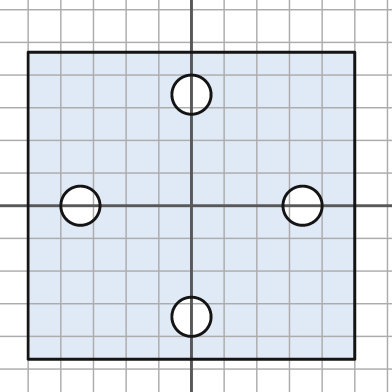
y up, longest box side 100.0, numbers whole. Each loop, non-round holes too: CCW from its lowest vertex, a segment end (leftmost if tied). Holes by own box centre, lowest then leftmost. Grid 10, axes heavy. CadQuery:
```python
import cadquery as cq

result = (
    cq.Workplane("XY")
    .moveTo(-50.0, -47.0)
    .lineTo(50.0, -47.0)
    .lineTo(50.0, 47.0)
    .lineTo(-50.0, 47.0)
    .close()
    .moveTo(0.0, -34.0)
    .circle(6.0)
    .moveTo(-34.0, 0.0)
    .circle(6.0)
    .moveTo(34.0, 0.0)
    .circle(6.0)
    .moveTo(0.0, 34.0)
    .circle(6.0)
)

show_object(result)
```